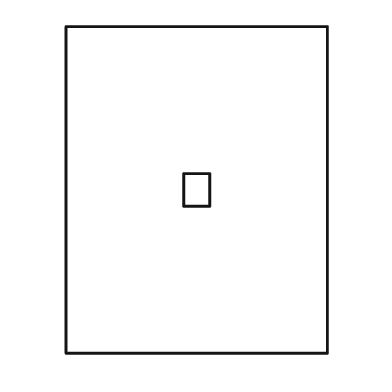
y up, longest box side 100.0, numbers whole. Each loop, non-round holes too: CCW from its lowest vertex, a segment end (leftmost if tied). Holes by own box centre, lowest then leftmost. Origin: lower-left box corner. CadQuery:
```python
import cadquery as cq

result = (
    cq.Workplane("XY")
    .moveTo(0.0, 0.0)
    .lineTo(80.0, 0.0)
    .lineTo(80.0, 100.0)
    .lineTo(0.0, 100.0)
    .close()
    .moveTo(36.0, 45.0)
    .lineTo(44.0, 45.0)
    .lineTo(44.0, 55.0)
    .lineTo(36.0, 55.0)
    .close()
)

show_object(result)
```